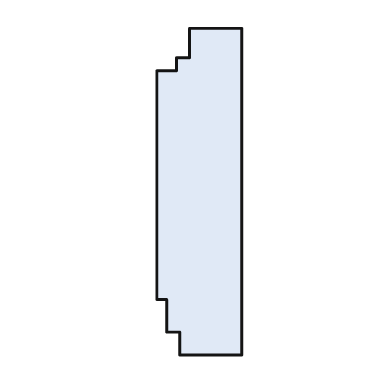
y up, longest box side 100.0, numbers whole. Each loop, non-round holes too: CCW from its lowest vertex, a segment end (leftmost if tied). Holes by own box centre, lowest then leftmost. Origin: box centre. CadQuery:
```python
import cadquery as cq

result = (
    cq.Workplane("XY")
    .moveTo(-6.0, -50.0)
    .lineTo(13.0, -50.0)
    .lineTo(13.0, 50.0)
    .lineTo(-3.0, 50.0)
    .lineTo(-3.0, 41.0)
    .lineTo(-7.0, 41.0)
    .lineTo(-7.0, 37.0)
    .lineTo(-13.0, 37.0)
    .lineTo(-13.0, -33.0)
    .lineTo(-10.0, -33.0)
    .lineTo(-10.0, -43.0)
    .lineTo(-6.0, -43.0)
    .close()
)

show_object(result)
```